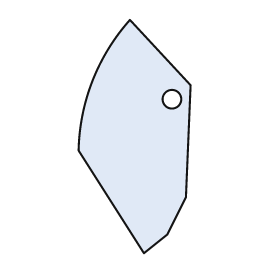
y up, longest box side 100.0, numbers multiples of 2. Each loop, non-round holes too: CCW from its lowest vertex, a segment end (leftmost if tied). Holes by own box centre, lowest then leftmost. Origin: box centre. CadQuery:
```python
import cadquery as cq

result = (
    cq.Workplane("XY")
    .moveTo(4.0, -50.0)
    .lineTo(14.0, -42.0)
    .lineTo(22.0, -26.0)
    .lineTo(24.0, 22.0)
    .lineTo(-2.0, 50.0)
    .threePointArc((-18.0, 24.0), (-24.0, -6.0))
    .close()
    .moveTo(16.0, 16.0)
    .circle(4.0)
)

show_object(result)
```